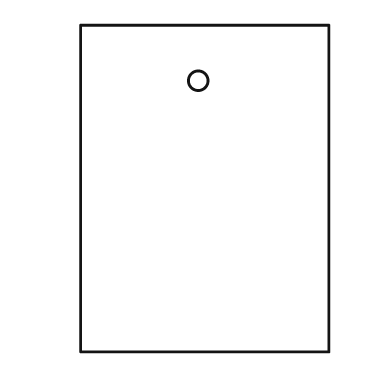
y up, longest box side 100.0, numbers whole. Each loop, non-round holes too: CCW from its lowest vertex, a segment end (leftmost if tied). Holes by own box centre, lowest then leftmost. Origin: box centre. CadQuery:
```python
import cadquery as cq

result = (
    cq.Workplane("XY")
    .moveTo(-38.0, -50.0)
    .lineTo(38.0, -50.0)
    .lineTo(38.0, 50.0)
    .lineTo(-38.0, 50.0)
    .close()
    .moveTo(-2.0, 33.0)
    .circle(3.0)
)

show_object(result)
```